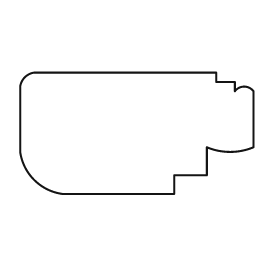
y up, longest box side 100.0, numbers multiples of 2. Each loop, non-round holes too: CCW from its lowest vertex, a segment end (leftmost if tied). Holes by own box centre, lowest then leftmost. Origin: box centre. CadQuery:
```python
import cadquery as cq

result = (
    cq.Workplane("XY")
    .moveTo(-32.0, -26.0)
    .lineTo(16.0, -26.0)
    .lineTo(16.0, -18.0)
    .lineTo(30.0, -18.0)
    .lineTo(30.0, -6.0)
    .threePointArc((40.0, -8.0), (50.0, -6.0))
    .lineTo(50.0, 18.0)
    .threePointArc((46.0, 20.0), (42.0, 18.0))
    .lineTo(42.0, 22.0)
    .lineTo(34.0, 22.0)
    .lineTo(34.0, 26.0)
    .lineTo(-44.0, 26.0)
    .threePointArc((-48.0, 24.0), (-50.0, 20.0))
    .lineTo(-50.0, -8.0)
    .threePointArc((-44.0, -20.0), (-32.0, -26.0))
    .close()
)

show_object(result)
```